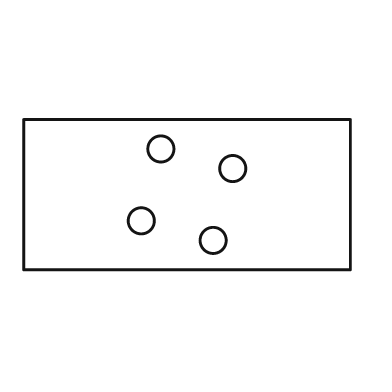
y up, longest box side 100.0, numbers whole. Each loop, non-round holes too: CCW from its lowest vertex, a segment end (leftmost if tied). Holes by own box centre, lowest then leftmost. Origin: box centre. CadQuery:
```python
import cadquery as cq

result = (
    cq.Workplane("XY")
    .moveTo(-50.0, -23.0)
    .lineTo(50.0, -23.0)
    .lineTo(50.0, 23.0)
    .lineTo(-50.0, 23.0)
    .close()
    .moveTo(8.0, -14.0)
    .circle(4.0)
    .moveTo(-14.0, -8.0)
    .circle(4.0)
    .moveTo(14.0, 8.0)
    .circle(4.0)
    .moveTo(-8.0, 14.0)
    .circle(4.0)
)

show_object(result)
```